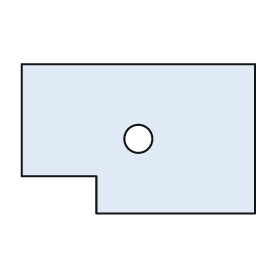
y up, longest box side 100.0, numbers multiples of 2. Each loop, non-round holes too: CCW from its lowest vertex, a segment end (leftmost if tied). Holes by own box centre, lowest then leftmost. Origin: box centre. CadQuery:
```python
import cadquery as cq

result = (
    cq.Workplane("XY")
    .moveTo(-18.0, -32.0)
    .lineTo(50.0, -32.0)
    .lineTo(50.0, 32.0)
    .lineTo(-50.0, 32.0)
    .lineTo(-50.0, -16.0)
    .lineTo(-18.0, -16.0)
    .close()
    .moveTo(0.0, 0.0)
    .circle(6.0)
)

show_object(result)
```